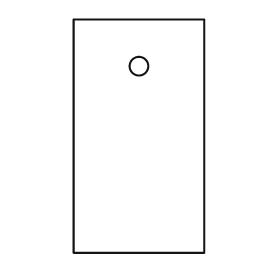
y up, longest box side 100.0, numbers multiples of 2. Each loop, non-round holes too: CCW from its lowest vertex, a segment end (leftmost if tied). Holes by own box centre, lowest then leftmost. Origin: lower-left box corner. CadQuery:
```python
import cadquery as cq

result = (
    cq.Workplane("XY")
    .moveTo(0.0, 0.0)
    .lineTo(56.0, 0.0)
    .lineTo(56.0, 100.0)
    .lineTo(0.0, 100.0)
    .close()
    .moveTo(28.0, 80.0)
    .circle(4.0)
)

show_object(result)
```